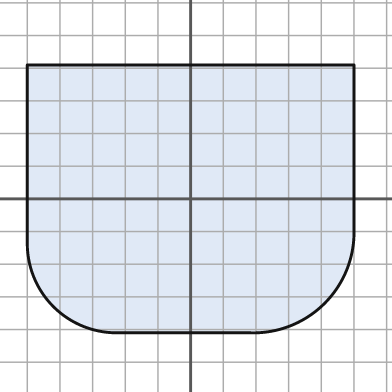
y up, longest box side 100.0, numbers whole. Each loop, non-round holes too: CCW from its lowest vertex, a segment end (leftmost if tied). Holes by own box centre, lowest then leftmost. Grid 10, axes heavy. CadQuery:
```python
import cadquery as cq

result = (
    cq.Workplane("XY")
    .moveTo(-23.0, -41.0)
    .lineTo(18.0, -41.0)
    .threePointArc((41.0, -32.0), (50.0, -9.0))
    .lineTo(50.0, 41.0)
    .lineTo(-50.0, 41.0)
    .lineTo(-50.0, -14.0)
    .threePointArc((-42.0, -33.0), (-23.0, -41.0))
    .close()
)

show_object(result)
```